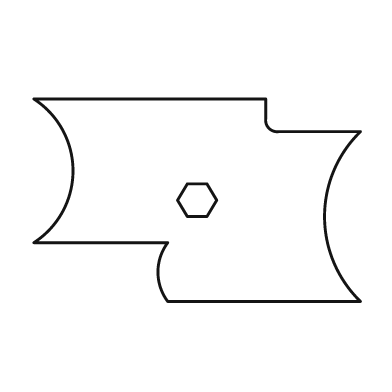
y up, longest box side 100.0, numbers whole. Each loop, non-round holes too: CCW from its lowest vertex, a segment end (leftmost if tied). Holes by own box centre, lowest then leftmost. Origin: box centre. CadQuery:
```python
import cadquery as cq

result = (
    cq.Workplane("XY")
    .moveTo(-9.0, -31.0)
    .lineTo(50.0, -31.0)
    .threePointArc((39.0, -5.0), (50.0, 21.0))
    .lineTo(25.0, 21.0)
    .threePointArc((22.0, 22.0), (21.0, 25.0))
    .lineTo(21.0, 31.0)
    .lineTo(-50.0, 31.0)
    .threePointArc((-38.0, 9.0), (-50.0, -13.0))
    .lineTo(-9.0, -13.0)
    .threePointArc((-12.0, -22.0), (-9.0, -31.0))
    .close()
    .moveTo(-3.0, -5.0)
    .lineTo(3.0, -5.0)
    .lineTo(6.0, 0.0)
    .lineTo(3.0, 5.0)
    .lineTo(-3.0, 5.0)
    .lineTo(-6.0, 0.0)
    .close()
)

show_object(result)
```